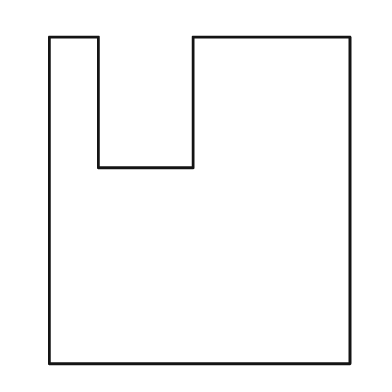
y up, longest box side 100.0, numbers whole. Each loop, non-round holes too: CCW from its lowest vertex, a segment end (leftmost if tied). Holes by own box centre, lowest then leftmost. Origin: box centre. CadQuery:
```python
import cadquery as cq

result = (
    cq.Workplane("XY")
    .moveTo(-46.0, -50.0)
    .lineTo(46.0, -50.0)
    .lineTo(46.0, 50.0)
    .lineTo(-2.0, 50.0)
    .lineTo(-2.0, 10.0)
    .lineTo(-31.0, 10.0)
    .lineTo(-31.0, 50.0)
    .lineTo(-46.0, 50.0)
    .close()
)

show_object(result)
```